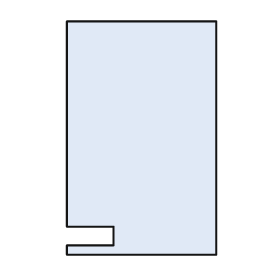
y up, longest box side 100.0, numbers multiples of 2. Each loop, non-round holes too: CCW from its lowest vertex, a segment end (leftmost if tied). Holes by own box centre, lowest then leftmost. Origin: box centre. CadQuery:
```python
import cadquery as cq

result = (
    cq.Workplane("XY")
    .moveTo(-32.0, -50.0)
    .lineTo(32.0, -50.0)
    .lineTo(32.0, 50.0)
    .lineTo(-32.0, 50.0)
    .lineTo(-32.0, -38.0)
    .lineTo(-12.0, -38.0)
    .lineTo(-12.0, -46.0)
    .lineTo(-32.0, -46.0)
    .close()
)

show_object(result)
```